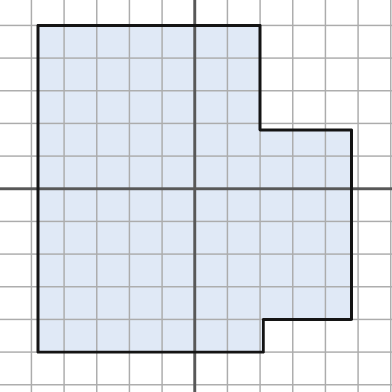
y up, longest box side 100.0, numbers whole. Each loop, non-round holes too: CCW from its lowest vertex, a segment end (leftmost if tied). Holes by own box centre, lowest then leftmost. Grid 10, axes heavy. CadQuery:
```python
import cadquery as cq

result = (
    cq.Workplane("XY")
    .moveTo(-48.0, -50.0)
    .lineTo(21.0, -50.0)
    .lineTo(21.0, -40.0)
    .lineTo(48.0, -40.0)
    .lineTo(48.0, 18.0)
    .lineTo(20.0, 18.0)
    .lineTo(20.0, 50.0)
    .lineTo(-48.0, 50.0)
    .close()
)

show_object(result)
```